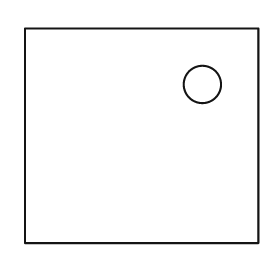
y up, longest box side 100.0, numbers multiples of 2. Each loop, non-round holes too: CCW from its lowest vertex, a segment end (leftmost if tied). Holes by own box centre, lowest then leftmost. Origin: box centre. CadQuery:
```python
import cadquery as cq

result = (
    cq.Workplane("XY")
    .moveTo(-50.0, -46.0)
    .lineTo(50.0, -46.0)
    .lineTo(50.0, 46.0)
    .lineTo(-50.0, 46.0)
    .close()
    .moveTo(26.0, 22.0)
    .circle(8.0)
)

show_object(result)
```